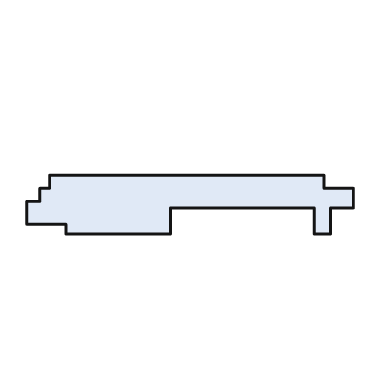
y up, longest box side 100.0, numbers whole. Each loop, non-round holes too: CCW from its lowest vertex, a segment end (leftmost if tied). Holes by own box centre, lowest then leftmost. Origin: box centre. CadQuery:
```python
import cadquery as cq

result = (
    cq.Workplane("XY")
    .moveTo(-38.0, -9.0)
    .lineTo(-6.0, -9.0)
    .lineTo(-6.0, -1.0)
    .lineTo(38.0, -1.0)
    .lineTo(38.0, -9.0)
    .lineTo(43.0, -9.0)
    .lineTo(43.0, -1.0)
    .lineTo(50.0, -1.0)
    .lineTo(50.0, 5.0)
    .lineTo(41.0, 5.0)
    .lineTo(41.0, 9.0)
    .lineTo(-43.0, 9.0)
    .lineTo(-43.0, 5.0)
    .lineTo(-46.0, 5.0)
    .lineTo(-46.0, 1.0)
    .lineTo(-50.0, 1.0)
    .lineTo(-50.0, -6.0)
    .lineTo(-38.0, -6.0)
    .close()
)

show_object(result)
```